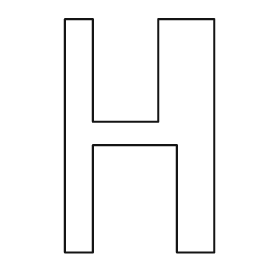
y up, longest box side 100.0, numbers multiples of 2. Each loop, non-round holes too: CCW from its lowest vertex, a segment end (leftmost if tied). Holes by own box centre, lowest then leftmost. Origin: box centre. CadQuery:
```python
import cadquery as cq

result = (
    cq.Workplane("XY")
    .moveTo(-32.0, -50.0)
    .lineTo(-20.0, -50.0)
    .lineTo(-20.0, -4.0)
    .lineTo(16.0, -4.0)
    .lineTo(16.0, -50.0)
    .lineTo(32.0, -50.0)
    .lineTo(32.0, 50.0)
    .lineTo(8.0, 50.0)
    .lineTo(8.0, 6.0)
    .lineTo(-20.0, 6.0)
    .lineTo(-20.0, 50.0)
    .lineTo(-32.0, 50.0)
    .close()
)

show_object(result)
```